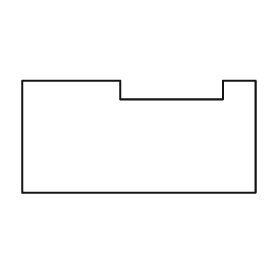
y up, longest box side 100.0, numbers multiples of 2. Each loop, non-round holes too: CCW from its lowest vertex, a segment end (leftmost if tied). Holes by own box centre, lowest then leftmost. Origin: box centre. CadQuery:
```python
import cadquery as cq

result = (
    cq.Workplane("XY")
    .moveTo(-50.0, -24.0)
    .lineTo(50.0, -24.0)
    .lineTo(50.0, 24.0)
    .lineTo(36.0, 24.0)
    .lineTo(36.0, 16.0)
    .lineTo(-8.0, 16.0)
    .lineTo(-8.0, 24.0)
    .lineTo(-50.0, 24.0)
    .close()
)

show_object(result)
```